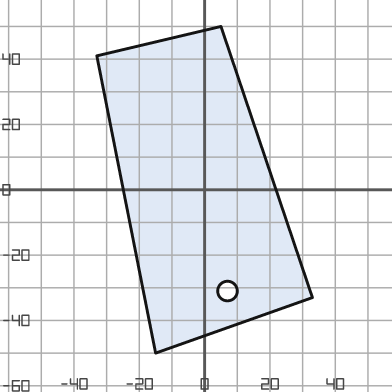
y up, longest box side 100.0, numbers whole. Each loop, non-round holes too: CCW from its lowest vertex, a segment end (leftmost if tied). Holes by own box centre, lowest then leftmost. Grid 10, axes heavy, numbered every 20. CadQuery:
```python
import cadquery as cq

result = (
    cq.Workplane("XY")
    .moveTo(-15.0, -50.0)
    .lineTo(33.0, -33.0)
    .lineTo(5.0, 50.0)
    .lineTo(-33.0, 41.0)
    .close()
    .moveTo(7.0, -31.0)
    .circle(3.0)
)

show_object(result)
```